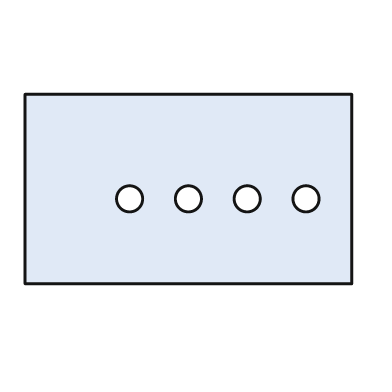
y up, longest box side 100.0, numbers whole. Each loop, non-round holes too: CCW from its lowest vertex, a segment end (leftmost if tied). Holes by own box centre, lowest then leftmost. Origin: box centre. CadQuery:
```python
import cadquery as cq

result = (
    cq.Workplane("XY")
    .moveTo(-50.0, -29.0)
    .lineTo(50.0, -29.0)
    .lineTo(50.0, 29.0)
    .lineTo(-50.0, 29.0)
    .close()
    .moveTo(-18.0, -3.0)
    .circle(4.0)
    .moveTo(0.0, -3.0)
    .circle(4.0)
    .moveTo(18.0, -3.0)
    .circle(4.0)
    .moveTo(36.0, -3.0)
    .circle(4.0)
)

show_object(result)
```